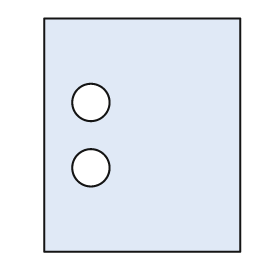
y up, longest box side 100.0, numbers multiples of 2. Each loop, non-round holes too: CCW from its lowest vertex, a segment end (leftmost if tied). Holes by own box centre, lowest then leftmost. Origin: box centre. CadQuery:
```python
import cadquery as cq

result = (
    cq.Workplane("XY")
    .moveTo(-42.0, -50.0)
    .lineTo(42.0, -50.0)
    .lineTo(42.0, 50.0)
    .lineTo(-42.0, 50.0)
    .close()
    .moveTo(-22.0, -14.0)
    .circle(8.0)
    .moveTo(-22.0, 14.0)
    .circle(8.0)
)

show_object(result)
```